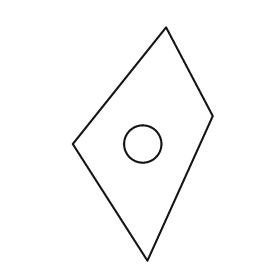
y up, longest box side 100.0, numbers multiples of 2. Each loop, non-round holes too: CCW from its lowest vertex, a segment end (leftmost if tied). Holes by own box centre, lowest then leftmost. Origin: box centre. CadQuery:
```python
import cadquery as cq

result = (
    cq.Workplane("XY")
    .moveTo(2.0, -50.0)
    .lineTo(30.0, 12.0)
    .lineTo(10.0, 50.0)
    .lineTo(-30.0, 0.0)
    .close()
    .moveTo(0.0, 0.0)
    .circle(8.0)
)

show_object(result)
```